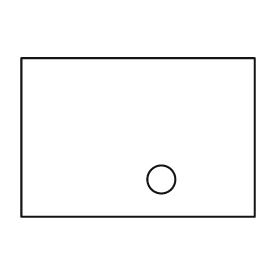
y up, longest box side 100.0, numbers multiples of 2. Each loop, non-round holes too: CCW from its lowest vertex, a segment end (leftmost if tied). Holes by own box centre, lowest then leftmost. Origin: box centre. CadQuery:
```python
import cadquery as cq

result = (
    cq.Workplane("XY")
    .moveTo(-50.0, -34.0)
    .lineTo(50.0, -34.0)
    .lineTo(50.0, 34.0)
    .lineTo(-50.0, 34.0)
    .close()
    .moveTo(10.0, -18.0)
    .circle(6.0)
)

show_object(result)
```